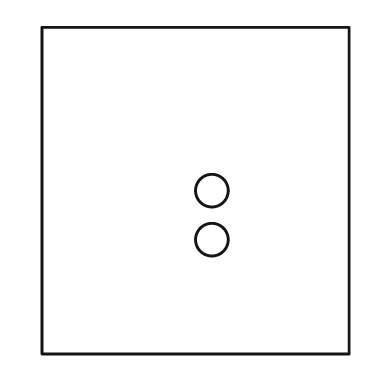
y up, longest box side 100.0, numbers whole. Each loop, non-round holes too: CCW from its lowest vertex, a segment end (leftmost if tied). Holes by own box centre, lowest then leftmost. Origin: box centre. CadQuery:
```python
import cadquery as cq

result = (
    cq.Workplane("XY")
    .moveTo(-47.0, -50.0)
    .lineTo(47.0, -50.0)
    .lineTo(47.0, 50.0)
    .lineTo(-47.0, 50.0)
    .close()
    .moveTo(5.0, -15.0)
    .circle(5.0)
    .moveTo(5.0, 0.0)
    .circle(5.0)
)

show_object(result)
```